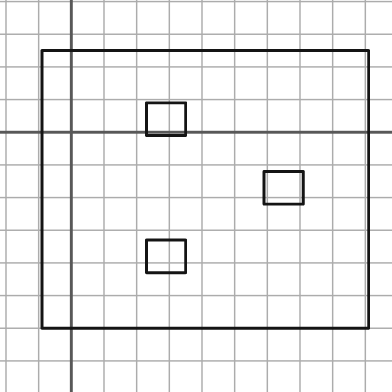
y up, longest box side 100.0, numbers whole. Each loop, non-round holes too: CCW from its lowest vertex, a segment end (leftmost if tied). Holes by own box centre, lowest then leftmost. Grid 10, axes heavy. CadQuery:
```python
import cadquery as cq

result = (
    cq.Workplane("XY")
    .moveTo(-9.0, -60.0)
    .lineTo(91.0, -60.0)
    .lineTo(91.0, 25.0)
    .lineTo(-9.0, 25.0)
    .close()
    .moveTo(23.0, -43.0)
    .lineTo(35.0, -43.0)
    .lineTo(35.0, -33.0)
    .lineTo(23.0, -33.0)
    .close()
    .moveTo(59.0, -22.0)
    .lineTo(71.0, -22.0)
    .lineTo(71.0, -12.0)
    .lineTo(59.0, -12.0)
    .close()
    .moveTo(23.0, -1.0)
    .lineTo(35.0, -1.0)
    .lineTo(35.0, 9.0)
    .lineTo(23.0, 9.0)
    .close()
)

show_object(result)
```